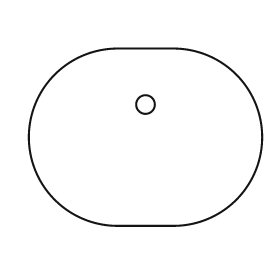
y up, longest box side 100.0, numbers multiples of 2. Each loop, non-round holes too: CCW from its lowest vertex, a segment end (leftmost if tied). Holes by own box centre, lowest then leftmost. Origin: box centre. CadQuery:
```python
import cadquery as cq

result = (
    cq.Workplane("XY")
    .moveTo(-12.0, -38.0)
    .lineTo(12.0, -38.0)
    .threePointArc((50.0, 0.0), (12.0, 38.0))
    .lineTo(-12.0, 38.0)
    .threePointArc((-50.0, 0.0), (-12.0, -38.0))
    .close()
    .moveTo(0.0, 14.0)
    .circle(4.0)
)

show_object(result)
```